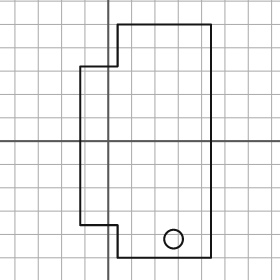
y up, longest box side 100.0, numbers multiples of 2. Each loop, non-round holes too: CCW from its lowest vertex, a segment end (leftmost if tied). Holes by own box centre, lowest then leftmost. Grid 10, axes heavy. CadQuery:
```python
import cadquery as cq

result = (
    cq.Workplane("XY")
    .moveTo(4.0, -50.0)
    .lineTo(44.0, -50.0)
    .lineTo(44.0, 50.0)
    .lineTo(4.0, 50.0)
    .lineTo(4.0, 32.0)
    .lineTo(-12.0, 32.0)
    .lineTo(-12.0, -36.0)
    .lineTo(4.0, -36.0)
    .close()
    .moveTo(28.0, -42.0)
    .circle(4.0)
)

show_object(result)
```